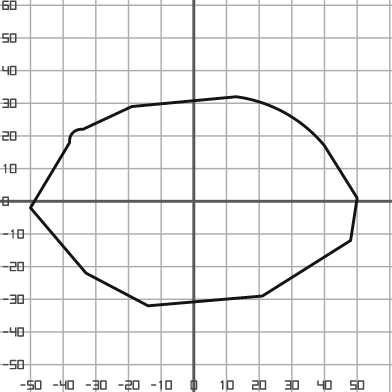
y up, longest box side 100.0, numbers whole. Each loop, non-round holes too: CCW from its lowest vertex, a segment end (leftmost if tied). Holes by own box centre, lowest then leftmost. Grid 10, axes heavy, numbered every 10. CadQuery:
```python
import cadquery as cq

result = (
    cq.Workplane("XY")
    .moveTo(-14.0, -32.0)
    .lineTo(21.0, -29.0)
    .lineTo(48.0, -12.0)
    .lineTo(50.0, 1.0)
    .lineTo(40.0, 17.0)
    .threePointArc((28.0, 27.0), (13.0, 32.0))
    .lineTo(-19.0, 29.0)
    .lineTo(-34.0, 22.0)
    .threePointArc((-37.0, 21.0), (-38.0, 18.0))
    .lineTo(-50.0, -2.0)
    .lineTo(-33.0, -22.0)
    .close()
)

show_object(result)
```